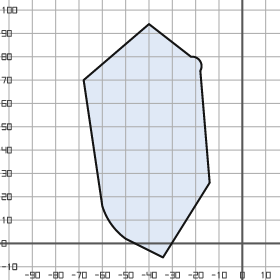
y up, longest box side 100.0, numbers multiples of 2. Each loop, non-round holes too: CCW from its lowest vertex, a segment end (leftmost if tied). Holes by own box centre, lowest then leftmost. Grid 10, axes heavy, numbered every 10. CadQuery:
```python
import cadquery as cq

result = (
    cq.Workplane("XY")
    .moveTo(-34.0, -6.0)
    .lineTo(-14.0, 26.0)
    .lineTo(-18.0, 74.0)
    .threePointArc((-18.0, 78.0), (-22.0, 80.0))
    .lineTo(-40.0, 94.0)
    .lineTo(-68.0, 70.0)
    .lineTo(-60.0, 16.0)
    .threePointArc((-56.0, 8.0), (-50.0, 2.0))
    .close()
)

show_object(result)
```